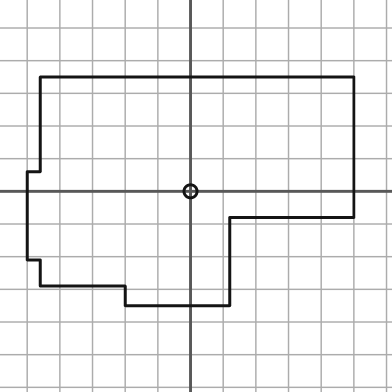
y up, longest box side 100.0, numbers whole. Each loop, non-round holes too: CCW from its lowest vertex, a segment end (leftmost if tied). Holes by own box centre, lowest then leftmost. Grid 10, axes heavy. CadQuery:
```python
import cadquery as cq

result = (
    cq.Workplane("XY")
    .moveTo(-20.0, -35.0)
    .lineTo(12.0, -35.0)
    .lineTo(12.0, -8.0)
    .lineTo(50.0, -8.0)
    .lineTo(50.0, 35.0)
    .lineTo(-46.0, 35.0)
    .lineTo(-46.0, 6.0)
    .lineTo(-50.0, 6.0)
    .lineTo(-50.0, -21.0)
    .lineTo(-46.0, -21.0)
    .lineTo(-46.0, -29.0)
    .lineTo(-20.0, -29.0)
    .close()
    .moveTo(0.0, 0.0)
    .circle(2.0)
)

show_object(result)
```